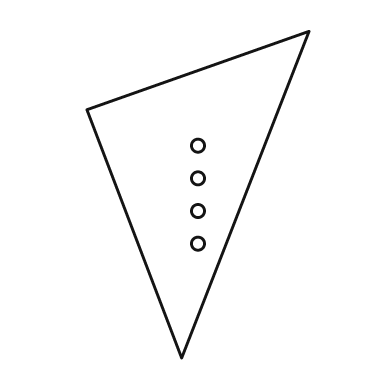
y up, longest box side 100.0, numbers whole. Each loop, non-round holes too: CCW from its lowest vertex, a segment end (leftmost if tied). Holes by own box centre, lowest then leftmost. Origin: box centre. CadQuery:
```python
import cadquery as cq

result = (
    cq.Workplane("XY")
    .moveTo(-5.0, -50.0)
    .lineTo(34.0, 50.0)
    .lineTo(-34.0, 26.0)
    .close()
    .moveTo(0.0, -15.0)
    .circle(2.0)
    .moveTo(0.0, -5.0)
    .circle(2.0)
    .moveTo(0.0, 5.0)
    .circle(2.0)
    .moveTo(0.0, 15.0)
    .circle(2.0)
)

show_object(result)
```